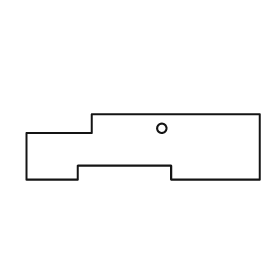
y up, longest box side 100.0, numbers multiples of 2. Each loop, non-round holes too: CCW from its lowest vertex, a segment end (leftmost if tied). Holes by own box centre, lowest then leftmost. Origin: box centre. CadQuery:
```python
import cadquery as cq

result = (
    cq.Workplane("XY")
    .moveTo(-50.0, -14.0)
    .lineTo(-28.0, -14.0)
    .lineTo(-28.0, -8.0)
    .lineTo(12.0, -8.0)
    .lineTo(12.0, -14.0)
    .lineTo(50.0, -14.0)
    .lineTo(50.0, 14.0)
    .lineTo(-22.0, 14.0)
    .lineTo(-22.0, 6.0)
    .lineTo(-50.0, 6.0)
    .close()
    .moveTo(8.0, 8.0)
    .circle(2.0)
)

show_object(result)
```